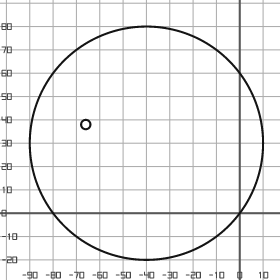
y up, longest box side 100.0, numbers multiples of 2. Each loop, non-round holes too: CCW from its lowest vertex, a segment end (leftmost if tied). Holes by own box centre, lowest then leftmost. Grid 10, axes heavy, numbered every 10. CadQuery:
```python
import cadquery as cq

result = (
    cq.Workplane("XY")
    .moveTo(-40.0, 30.0)
    .circle(50.0)
    .moveTo(-66.0, 38.0)
    .circle(2.0)
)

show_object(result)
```